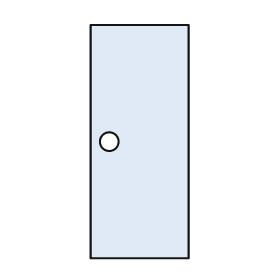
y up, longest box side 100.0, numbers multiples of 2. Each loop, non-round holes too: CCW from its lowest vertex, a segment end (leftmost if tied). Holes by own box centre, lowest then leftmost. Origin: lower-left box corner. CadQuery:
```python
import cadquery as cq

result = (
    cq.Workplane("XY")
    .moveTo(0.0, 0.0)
    .lineTo(42.0, 0.0)
    .lineTo(42.0, 100.0)
    .lineTo(0.0, 100.0)
    .close()
    .moveTo(8.0, 50.0)
    .circle(4.0)
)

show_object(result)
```